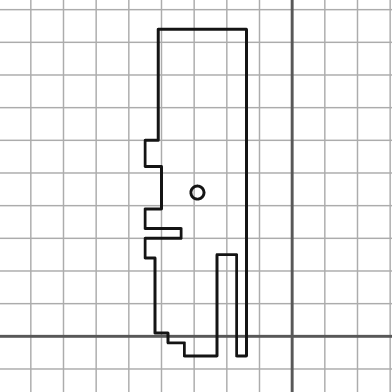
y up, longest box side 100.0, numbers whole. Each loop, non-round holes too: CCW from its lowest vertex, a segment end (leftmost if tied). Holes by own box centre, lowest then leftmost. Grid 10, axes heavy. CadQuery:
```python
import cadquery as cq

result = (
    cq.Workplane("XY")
    .moveTo(-33.0, -6.0)
    .lineTo(-23.0, -6.0)
    .lineTo(-23.0, 25.0)
    .lineTo(-17.0, 25.0)
    .lineTo(-17.0, -6.0)
    .lineTo(-14.0, -6.0)
    .lineTo(-14.0, 94.0)
    .lineTo(-41.0, 94.0)
    .lineTo(-41.0, 60.0)
    .lineTo(-45.0, 60.0)
    .lineTo(-45.0, 52.0)
    .lineTo(-40.0, 52.0)
    .lineTo(-40.0, 39.0)
    .lineTo(-45.0, 39.0)
    .lineTo(-45.0, 33.0)
    .lineTo(-34.0, 33.0)
    .lineTo(-34.0, 30.0)
    .lineTo(-45.0, 30.0)
    .lineTo(-45.0, 24.0)
    .lineTo(-42.0, 24.0)
    .lineTo(-42.0, 1.0)
    .lineTo(-38.0, 1.0)
    .lineTo(-38.0, -2.0)
    .lineTo(-33.0, -2.0)
    .close()
    .moveTo(-29.0, 44.0)
    .circle(2.0)
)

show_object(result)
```